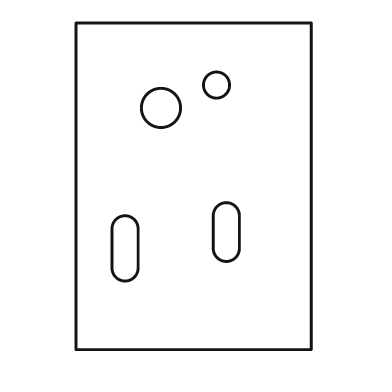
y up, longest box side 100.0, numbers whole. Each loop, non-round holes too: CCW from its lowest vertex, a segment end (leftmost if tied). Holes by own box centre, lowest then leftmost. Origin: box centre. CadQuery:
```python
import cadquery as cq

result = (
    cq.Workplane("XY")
    .moveTo(-36.0, -50.0)
    .lineTo(36.0, -50.0)
    .lineTo(36.0, 50.0)
    .lineTo(-36.0, 50.0)
    .close()
    .moveTo(-25.0, -25.0)
    .threePointArc((-21.0, -29.0), (-17.0, -25.0))
    .lineTo(-17.0, -13.0)
    .threePointArc((-21.0, -9.0), (-25.0, -13.0))
    .close()
    .moveTo(6.0, -19.0)
    .threePointArc((10.0, -23.0), (14.0, -19.0))
    .lineTo(14.0, -9.0)
    .threePointArc((10.0, -5.0), (6.0, -9.0))
    .close()
    .moveTo(-10.0, 24.0)
    .circle(6.0)
    .moveTo(7.0, 31.0)
    .circle(4.0)
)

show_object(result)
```